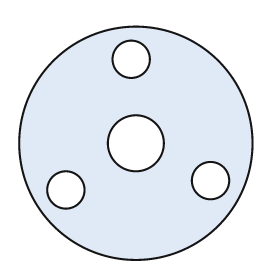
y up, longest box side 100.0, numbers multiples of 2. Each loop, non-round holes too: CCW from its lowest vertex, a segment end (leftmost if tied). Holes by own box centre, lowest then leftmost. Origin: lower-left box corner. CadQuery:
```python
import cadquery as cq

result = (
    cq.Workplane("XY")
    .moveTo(50.0, 50.0)
    .circle(50.0)
    .moveTo(20.0, 30.0)
    .circle(8.0)
    .moveTo(82.0, 34.0)
    .circle(8.0)
    .moveTo(50.0, 50.0)
    .circle(12.0)
    .moveTo(48.0, 86.0)
    .circle(8.0)
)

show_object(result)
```